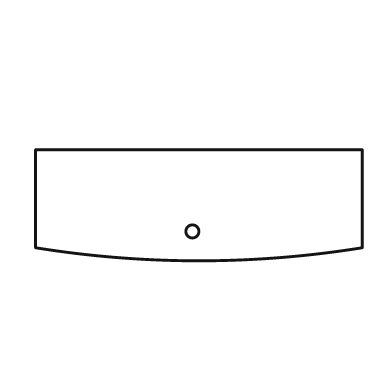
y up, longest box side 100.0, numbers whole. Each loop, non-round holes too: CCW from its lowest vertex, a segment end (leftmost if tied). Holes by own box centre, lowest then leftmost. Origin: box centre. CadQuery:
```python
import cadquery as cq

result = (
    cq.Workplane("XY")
    .moveTo(-50.0, -13.0)
    .threePointArc((0.0, -17.0), (50.0, -13.0))
    .lineTo(50.0, 17.0)
    .lineTo(-50.0, 17.0)
    .close()
    .moveTo(-2.0, -8.0)
    .circle(2.0)
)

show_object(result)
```